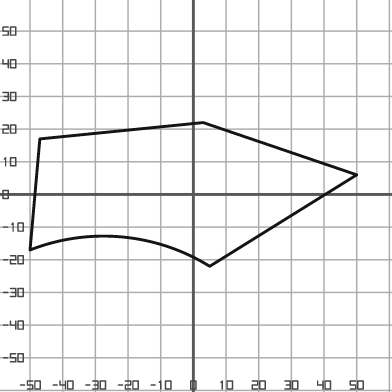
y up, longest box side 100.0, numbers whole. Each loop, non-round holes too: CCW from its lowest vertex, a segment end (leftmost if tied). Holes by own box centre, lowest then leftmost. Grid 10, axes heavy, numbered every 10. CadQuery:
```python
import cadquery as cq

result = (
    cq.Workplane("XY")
    .moveTo(5.0, -22.0)
    .lineTo(50.0, 6.0)
    .lineTo(3.0, 22.0)
    .lineTo(-47.0, 17.0)
    .lineTo(-50.0, -17.0)
    .threePointArc((-22.0, -13.0), (5.0, -22.0))
    .close()
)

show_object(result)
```